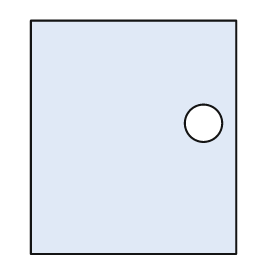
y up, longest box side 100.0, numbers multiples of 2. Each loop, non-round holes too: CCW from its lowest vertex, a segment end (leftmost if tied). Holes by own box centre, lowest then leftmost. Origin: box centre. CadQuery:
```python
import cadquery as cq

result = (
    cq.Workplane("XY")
    .moveTo(-44.0, -50.0)
    .lineTo(44.0, -50.0)
    .lineTo(44.0, 50.0)
    .lineTo(-44.0, 50.0)
    .close()
    .moveTo(30.0, 6.0)
    .circle(8.0)
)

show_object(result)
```